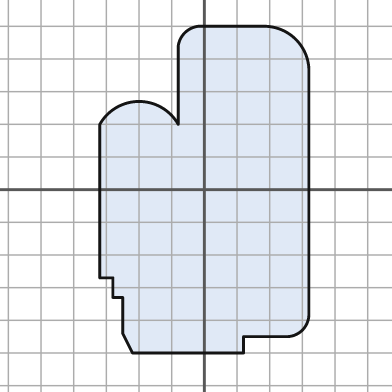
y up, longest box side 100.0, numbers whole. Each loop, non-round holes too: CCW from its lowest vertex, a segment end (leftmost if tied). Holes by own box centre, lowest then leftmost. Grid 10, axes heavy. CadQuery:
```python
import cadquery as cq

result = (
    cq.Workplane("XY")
    .moveTo(-22.0, -50.0)
    .lineTo(12.0, -50.0)
    .lineTo(12.0, -45.0)
    .lineTo(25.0, -45.0)
    .threePointArc((30.0, -43.0), (32.0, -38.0))
    .lineTo(32.0, 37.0)
    .threePointArc((28.0, 46.0), (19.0, 50.0))
    .lineTo(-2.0, 50.0)
    .threePointArc((-6.0, 48.0), (-8.0, 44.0))
    .lineTo(-8.0, 20.0)
    .threePointArc((-20.0, 27.0), (-32.0, 20.0))
    .lineTo(-32.0, -27.0)
    .lineTo(-28.0, -27.0)
    .lineTo(-28.0, -33.0)
    .lineTo(-25.0, -33.0)
    .lineTo(-25.0, -44.0)
    .close()
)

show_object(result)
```